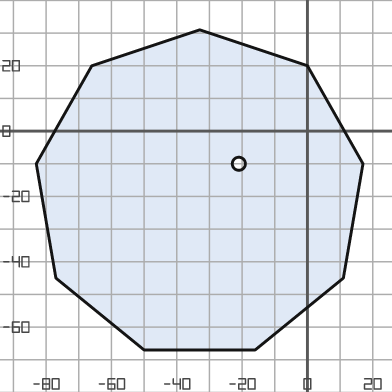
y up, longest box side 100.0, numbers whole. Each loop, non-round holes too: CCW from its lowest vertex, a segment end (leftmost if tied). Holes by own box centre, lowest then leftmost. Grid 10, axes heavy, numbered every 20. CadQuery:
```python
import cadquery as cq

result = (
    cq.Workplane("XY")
    .moveTo(-50.0, -67.0)
    .lineTo(-16.0, -67.0)
    .lineTo(11.0, -45.0)
    .lineTo(17.0, -10.0)
    .lineTo(0.0, 20.0)
    .lineTo(-33.0, 31.0)
    .lineTo(-66.0, 20.0)
    .lineTo(-83.0, -10.0)
    .lineTo(-77.0, -45.0)
    .close()
    .moveTo(-21.0, -10.0)
    .circle(2.0)
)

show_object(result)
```